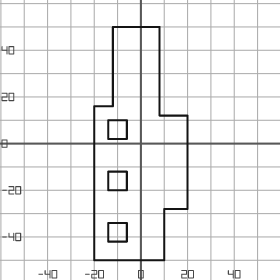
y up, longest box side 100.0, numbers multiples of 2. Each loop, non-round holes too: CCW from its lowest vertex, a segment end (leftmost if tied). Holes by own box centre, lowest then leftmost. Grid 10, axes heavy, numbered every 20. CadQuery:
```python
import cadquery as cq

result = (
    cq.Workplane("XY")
    .moveTo(-20.0, -50.0)
    .lineTo(10.0, -50.0)
    .lineTo(10.0, -28.0)
    .lineTo(20.0, -28.0)
    .lineTo(20.0, 12.0)
    .lineTo(8.0, 12.0)
    .lineTo(8.0, 50.0)
    .lineTo(-12.0, 50.0)
    .lineTo(-12.0, 16.0)
    .lineTo(-20.0, 16.0)
    .close()
    .moveTo(-14.0, -42.0)
    .lineTo(-6.0, -42.0)
    .lineTo(-6.0, -34.0)
    .lineTo(-14.0, -34.0)
    .close()
    .moveTo(-14.0, -20.0)
    .lineTo(-6.0, -20.0)
    .lineTo(-6.0, -12.0)
    .lineTo(-14.0, -12.0)
    .close()
    .moveTo(-14.0, 2.0)
    .lineTo(-6.0, 2.0)
    .lineTo(-6.0, 10.0)
    .lineTo(-14.0, 10.0)
    .close()
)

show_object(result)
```